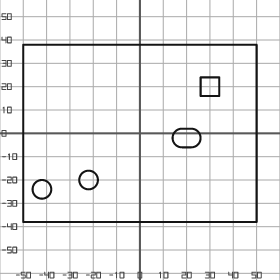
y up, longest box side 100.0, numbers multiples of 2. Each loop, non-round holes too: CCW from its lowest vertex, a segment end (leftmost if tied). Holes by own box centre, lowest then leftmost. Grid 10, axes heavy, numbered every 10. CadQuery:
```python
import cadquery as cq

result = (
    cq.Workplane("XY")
    .moveTo(-50.0, -38.0)
    .lineTo(50.0, -38.0)
    .lineTo(50.0, 38.0)
    .lineTo(-50.0, 38.0)
    .close()
    .moveTo(-42.0, -24.0)
    .circle(4.0)
    .moveTo(-22.0, -20.0)
    .circle(4.0)
    .moveTo(18.0, -6.0)
    .lineTo(22.0, -6.0)
    .threePointArc((26.0, -2.0), (22.0, 2.0))
    .lineTo(18.0, 2.0)
    .threePointArc((14.0, -2.0), (18.0, -6.0))
    .close()
    .moveTo(26.0, 16.0)
    .lineTo(34.0, 16.0)
    .lineTo(34.0, 24.0)
    .lineTo(26.0, 24.0)
    .close()
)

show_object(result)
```